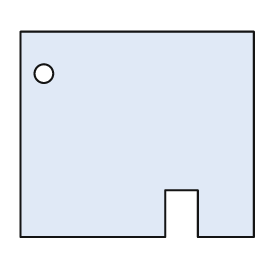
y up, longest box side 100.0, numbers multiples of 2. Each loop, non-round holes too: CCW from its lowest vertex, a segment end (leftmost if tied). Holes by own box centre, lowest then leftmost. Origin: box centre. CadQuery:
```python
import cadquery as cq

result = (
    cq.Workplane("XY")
    .moveTo(-50.0, -44.0)
    .lineTo(12.0, -44.0)
    .lineTo(12.0, -24.0)
    .lineTo(26.0, -24.0)
    .lineTo(26.0, -44.0)
    .lineTo(50.0, -44.0)
    .lineTo(50.0, 44.0)
    .lineTo(-50.0, 44.0)
    .close()
    .moveTo(-40.0, 26.0)
    .circle(4.0)
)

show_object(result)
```